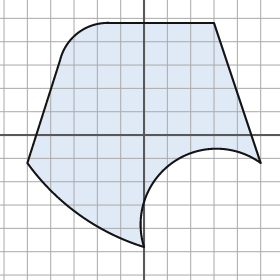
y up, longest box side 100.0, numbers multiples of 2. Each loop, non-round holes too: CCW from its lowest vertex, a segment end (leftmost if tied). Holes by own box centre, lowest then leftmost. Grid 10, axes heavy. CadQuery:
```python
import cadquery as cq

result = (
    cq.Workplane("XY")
    .moveTo(0.0, -48.0)
    .threePointArc((12.0, -12.0), (50.0, -12.0))
    .lineTo(30.0, 48.0)
    .lineTo(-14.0, 48.0)
    .threePointArc((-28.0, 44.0), (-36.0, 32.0))
    .lineTo(-50.0, -12.0)
    .threePointArc((-28.0, -34.0), (0.0, -48.0))
    .close()
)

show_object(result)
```